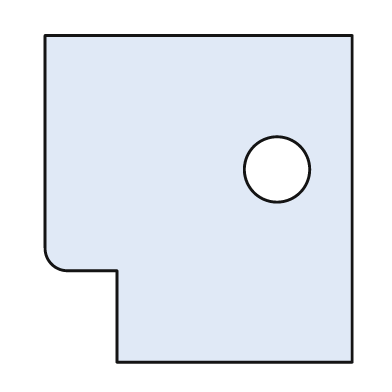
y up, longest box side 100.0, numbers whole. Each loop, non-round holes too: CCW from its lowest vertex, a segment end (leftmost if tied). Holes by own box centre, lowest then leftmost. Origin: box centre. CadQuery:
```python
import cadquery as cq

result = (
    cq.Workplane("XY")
    .moveTo(-25.0, -50.0)
    .lineTo(47.0, -50.0)
    .lineTo(47.0, 50.0)
    .lineTo(-47.0, 50.0)
    .lineTo(-47.0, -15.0)
    .threePointArc((-45.0, -20.0), (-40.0, -22.0))
    .lineTo(-25.0, -22.0)
    .close()
    .moveTo(24.0, 9.0)
    .circle(10.0)
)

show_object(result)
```